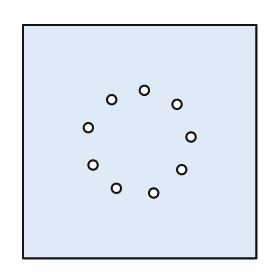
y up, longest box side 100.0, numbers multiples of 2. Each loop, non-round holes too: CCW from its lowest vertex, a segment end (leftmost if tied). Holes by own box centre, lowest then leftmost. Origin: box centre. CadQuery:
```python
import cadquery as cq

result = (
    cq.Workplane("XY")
    .moveTo(-50.0, -50.0)
    .lineTo(50.0, -50.0)
    .lineTo(50.0, 50.0)
    .lineTo(-50.0, 50.0)
    .close()
    .moveTo(6.0, -22.0)
    .circle(2.0)
    .moveTo(-10.0, -20.0)
    .circle(2.0)
    .moveTo(18.0, -12.0)
    .circle(2.0)
    .moveTo(-20.0, -10.0)
    .circle(2.0)
    .moveTo(22.0, 2.0)
    .circle(2.0)
    .moveTo(-22.0, 6.0)
    .circle(2.0)
    .moveTo(16.0, 16.0)
    .circle(2.0)
    .moveTo(-12.0, 18.0)
    .circle(2.0)
    .moveTo(2.0, 22.0)
    .circle(2.0)
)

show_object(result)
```